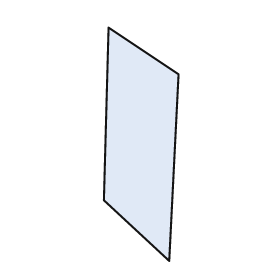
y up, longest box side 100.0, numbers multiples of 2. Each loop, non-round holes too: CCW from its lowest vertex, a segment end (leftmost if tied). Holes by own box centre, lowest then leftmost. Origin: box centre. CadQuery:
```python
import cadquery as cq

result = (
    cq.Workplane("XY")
    .moveTo(12.0, -50.0)
    .lineTo(16.0, 30.0)
    .lineTo(-14.0, 50.0)
    .lineTo(-16.0, -24.0)
    .close()
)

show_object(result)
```